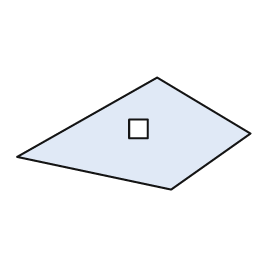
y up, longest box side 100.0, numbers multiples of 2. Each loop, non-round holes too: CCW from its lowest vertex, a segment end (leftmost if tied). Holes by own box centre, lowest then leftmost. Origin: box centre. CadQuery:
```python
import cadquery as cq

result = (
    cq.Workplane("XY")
    .moveTo(16.0, -24.0)
    .lineTo(50.0, 0.0)
    .lineTo(10.0, 24.0)
    .lineTo(-50.0, -10.0)
    .close()
    .moveTo(-2.0, -2.0)
    .lineTo(6.0, -2.0)
    .lineTo(6.0, 6.0)
    .lineTo(-2.0, 6.0)
    .close()
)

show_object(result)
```